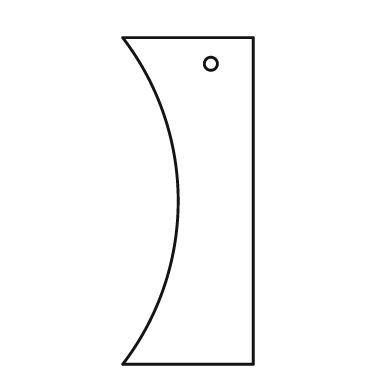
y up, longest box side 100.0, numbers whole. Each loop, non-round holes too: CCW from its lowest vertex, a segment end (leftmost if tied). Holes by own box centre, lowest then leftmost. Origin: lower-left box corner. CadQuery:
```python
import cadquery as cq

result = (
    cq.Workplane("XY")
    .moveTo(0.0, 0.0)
    .lineTo(40.0, 0.0)
    .lineTo(40.0, 100.0)
    .lineTo(0.0, 100.0)
    .threePointArc((17.0, 50.0), (0.0, 0.0))
    .close()
    .moveTo(27.0, 92.0)
    .circle(2.0)
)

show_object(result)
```